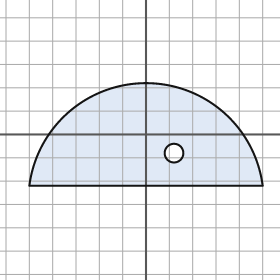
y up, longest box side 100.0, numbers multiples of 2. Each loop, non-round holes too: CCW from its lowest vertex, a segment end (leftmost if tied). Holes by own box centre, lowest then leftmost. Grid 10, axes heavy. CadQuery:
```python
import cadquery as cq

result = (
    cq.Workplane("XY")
    .moveTo(-50.0, -22.0)
    .lineTo(50.0, -22.0)
    .threePointArc((0.0, 22.0), (-50.0, -22.0))
    .close()
    .moveTo(12.0, -8.0)
    .circle(4.0)
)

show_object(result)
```